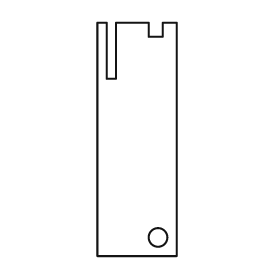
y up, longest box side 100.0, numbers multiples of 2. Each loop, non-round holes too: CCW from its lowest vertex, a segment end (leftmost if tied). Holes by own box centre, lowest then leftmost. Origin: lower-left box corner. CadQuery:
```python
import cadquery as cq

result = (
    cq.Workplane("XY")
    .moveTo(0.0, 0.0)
    .lineTo(34.0, 0.0)
    .lineTo(34.0, 100.0)
    .lineTo(28.0, 100.0)
    .lineTo(28.0, 94.0)
    .lineTo(22.0, 94.0)
    .lineTo(22.0, 100.0)
    .lineTo(8.0, 100.0)
    .lineTo(8.0, 76.0)
    .lineTo(4.0, 76.0)
    .lineTo(4.0, 100.0)
    .lineTo(0.0, 100.0)
    .close()
    .moveTo(26.0, 8.0)
    .circle(4.0)
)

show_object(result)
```